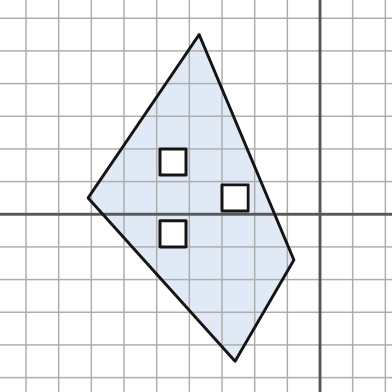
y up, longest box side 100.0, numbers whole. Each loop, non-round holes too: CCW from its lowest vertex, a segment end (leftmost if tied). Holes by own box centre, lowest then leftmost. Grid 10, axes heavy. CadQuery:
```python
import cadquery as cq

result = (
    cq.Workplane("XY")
    .moveTo(-26.0, -45.0)
    .lineTo(-8.0, -14.0)
    .lineTo(-37.0, 55.0)
    .lineTo(-71.0, 5.0)
    .close()
    .moveTo(-49.0, -10.0)
    .lineTo(-41.0, -10.0)
    .lineTo(-41.0, -2.0)
    .lineTo(-49.0, -2.0)
    .close()
    .moveTo(-30.0, 1.0)
    .lineTo(-22.0, 1.0)
    .lineTo(-22.0, 9.0)
    .lineTo(-30.0, 9.0)
    .close()
    .moveTo(-49.0, 12.0)
    .lineTo(-41.0, 12.0)
    .lineTo(-41.0, 20.0)
    .lineTo(-49.0, 20.0)
    .close()
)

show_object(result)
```